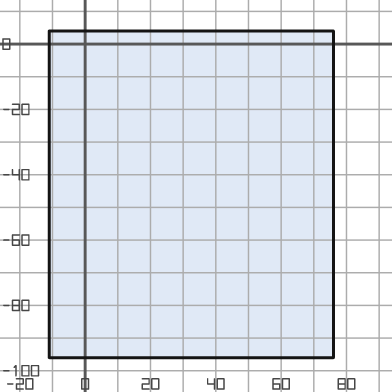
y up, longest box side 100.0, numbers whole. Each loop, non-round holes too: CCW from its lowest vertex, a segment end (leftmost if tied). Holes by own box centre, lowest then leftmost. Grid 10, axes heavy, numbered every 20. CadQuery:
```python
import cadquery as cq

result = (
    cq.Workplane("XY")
    .moveTo(-11.0, -96.0)
    .lineTo(76.0, -96.0)
    .lineTo(76.0, 4.0)
    .lineTo(-11.0, 4.0)
    .close()
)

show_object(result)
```